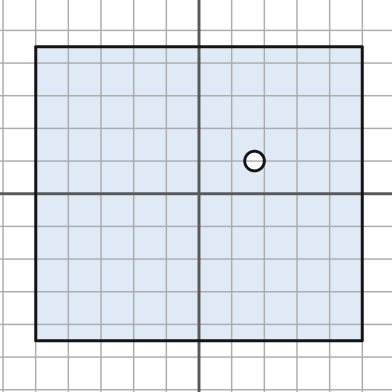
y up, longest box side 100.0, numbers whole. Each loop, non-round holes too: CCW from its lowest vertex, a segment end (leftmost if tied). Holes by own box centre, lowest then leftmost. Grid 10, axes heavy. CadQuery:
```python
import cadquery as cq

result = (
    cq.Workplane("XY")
    .moveTo(-50.0, -45.0)
    .lineTo(50.0, -45.0)
    .lineTo(50.0, 45.0)
    .lineTo(-50.0, 45.0)
    .close()
    .moveTo(17.0, 10.0)
    .circle(3.0)
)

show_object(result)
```